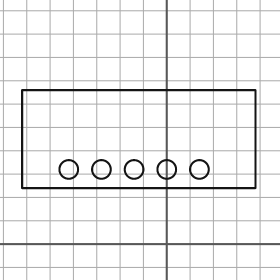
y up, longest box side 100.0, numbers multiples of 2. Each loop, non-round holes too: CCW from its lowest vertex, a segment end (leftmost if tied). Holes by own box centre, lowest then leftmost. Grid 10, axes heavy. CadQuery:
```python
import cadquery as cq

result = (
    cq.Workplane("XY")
    .moveTo(-62.0, 24.0)
    .lineTo(38.0, 24.0)
    .lineTo(38.0, 66.0)
    .lineTo(-62.0, 66.0)
    .close()
    .moveTo(-42.0, 32.0)
    .circle(4.0)
    .moveTo(-28.0, 32.0)
    .circle(4.0)
    .moveTo(-14.0, 32.0)
    .circle(4.0)
    .moveTo(0.0, 32.0)
    .circle(4.0)
    .moveTo(14.0, 32.0)
    .circle(4.0)
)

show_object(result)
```